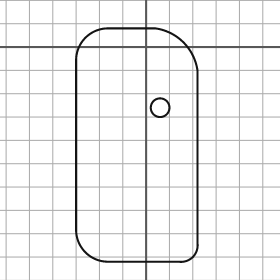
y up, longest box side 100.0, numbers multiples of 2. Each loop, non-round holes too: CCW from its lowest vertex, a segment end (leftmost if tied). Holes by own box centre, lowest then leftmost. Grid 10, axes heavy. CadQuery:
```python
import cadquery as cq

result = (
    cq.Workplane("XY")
    .moveTo(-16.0, -92.0)
    .lineTo(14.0, -92.0)
    .threePointArc((20.0, -90.0), (22.0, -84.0))
    .lineTo(22.0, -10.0)
    .threePointArc((16.0, 2.0), (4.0, 8.0))
    .lineTo(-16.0, 8.0)
    .threePointArc((-26.0, 4.0), (-30.0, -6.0))
    .lineTo(-30.0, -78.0)
    .threePointArc((-26.0, -88.0), (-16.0, -92.0))
    .close()
    .moveTo(6.0, -26.0)
    .circle(4.0)
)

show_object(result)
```